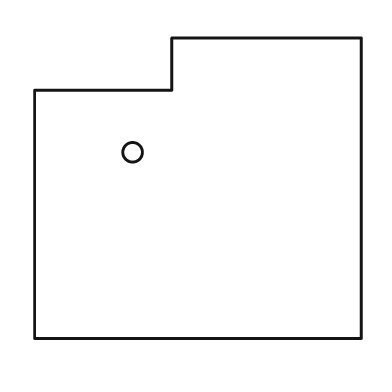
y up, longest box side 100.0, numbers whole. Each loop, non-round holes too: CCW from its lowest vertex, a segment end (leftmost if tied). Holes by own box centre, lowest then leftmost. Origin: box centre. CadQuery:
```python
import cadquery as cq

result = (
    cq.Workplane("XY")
    .moveTo(-50.0, -46.0)
    .lineTo(50.0, -46.0)
    .lineTo(50.0, 46.0)
    .lineTo(-8.0, 46.0)
    .lineTo(-8.0, 30.0)
    .lineTo(-50.0, 30.0)
    .close()
    .moveTo(-20.0, 11.0)
    .circle(3.0)
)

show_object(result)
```